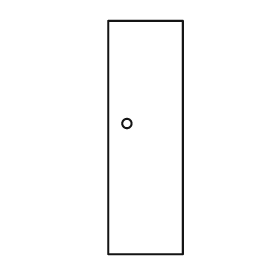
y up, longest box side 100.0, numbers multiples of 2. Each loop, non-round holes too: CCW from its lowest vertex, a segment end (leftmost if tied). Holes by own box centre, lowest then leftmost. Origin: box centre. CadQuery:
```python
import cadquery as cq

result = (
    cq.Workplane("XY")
    .moveTo(-16.0, -50.0)
    .lineTo(16.0, -50.0)
    .lineTo(16.0, 50.0)
    .lineTo(-16.0, 50.0)
    .close()
    .moveTo(-8.0, 6.0)
    .circle(2.0)
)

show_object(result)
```